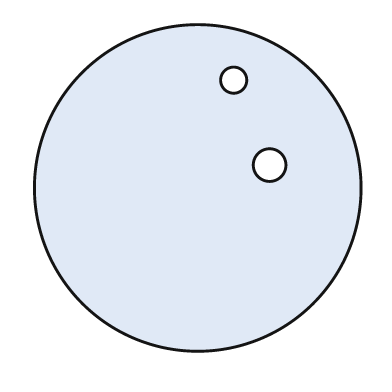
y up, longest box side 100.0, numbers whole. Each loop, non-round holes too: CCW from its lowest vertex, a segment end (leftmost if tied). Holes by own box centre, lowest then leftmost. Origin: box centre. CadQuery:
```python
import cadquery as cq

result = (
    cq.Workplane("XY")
    .moveTo(0.0, 0.0)
    .circle(50.0)
    .moveTo(22.0, 7.0)
    .circle(5.0)
    .moveTo(11.0, 33.0)
    .circle(4.0)
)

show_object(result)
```